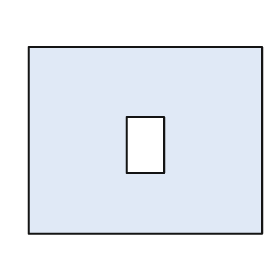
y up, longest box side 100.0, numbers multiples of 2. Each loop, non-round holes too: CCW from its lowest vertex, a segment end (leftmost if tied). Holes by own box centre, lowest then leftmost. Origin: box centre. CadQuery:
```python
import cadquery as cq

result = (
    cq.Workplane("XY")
    .moveTo(-50.0, -40.0)
    .lineTo(50.0, -40.0)
    .lineTo(50.0, 40.0)
    .lineTo(-50.0, 40.0)
    .close()
    .moveTo(-8.0, -14.0)
    .lineTo(8.0, -14.0)
    .lineTo(8.0, 10.0)
    .lineTo(-8.0, 10.0)
    .close()
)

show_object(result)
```